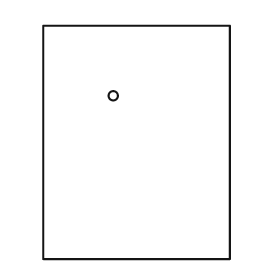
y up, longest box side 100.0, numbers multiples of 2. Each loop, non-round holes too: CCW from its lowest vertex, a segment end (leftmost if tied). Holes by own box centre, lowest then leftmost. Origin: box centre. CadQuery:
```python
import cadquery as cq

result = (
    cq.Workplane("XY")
    .moveTo(-40.0, -50.0)
    .lineTo(40.0, -50.0)
    .lineTo(40.0, 50.0)
    .lineTo(-40.0, 50.0)
    .close()
    .moveTo(-10.0, 20.0)
    .circle(2.0)
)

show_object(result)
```